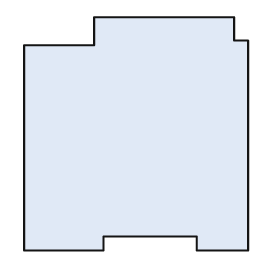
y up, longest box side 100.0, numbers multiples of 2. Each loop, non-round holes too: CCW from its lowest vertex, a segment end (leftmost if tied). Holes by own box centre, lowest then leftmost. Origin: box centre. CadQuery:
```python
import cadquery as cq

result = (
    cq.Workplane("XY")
    .moveTo(-48.0, -50.0)
    .lineTo(-14.0, -50.0)
    .lineTo(-14.0, -44.0)
    .lineTo(26.0, -44.0)
    .lineTo(26.0, -50.0)
    .lineTo(48.0, -50.0)
    .lineTo(48.0, 40.0)
    .lineTo(42.0, 40.0)
    .lineTo(42.0, 50.0)
    .lineTo(-18.0, 50.0)
    .lineTo(-18.0, 38.0)
    .lineTo(-48.0, 38.0)
    .close()
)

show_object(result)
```